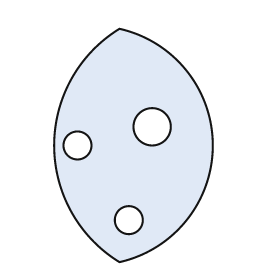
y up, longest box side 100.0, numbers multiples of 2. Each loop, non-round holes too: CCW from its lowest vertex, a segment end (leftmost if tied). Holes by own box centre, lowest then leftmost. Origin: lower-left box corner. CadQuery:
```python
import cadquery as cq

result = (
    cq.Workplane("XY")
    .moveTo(28.0, 0.0)
    .threePointArc((68.0, 50.0), (28.0, 100.0))
    .threePointArc((0.0, 50.0), (28.0, 0.0))
    .close()
    .moveTo(32.0, 18.0)
    .circle(6.0)
    .moveTo(10.0, 50.0)
    .circle(6.0)
    .moveTo(42.0, 58.0)
    .circle(8.0)
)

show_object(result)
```